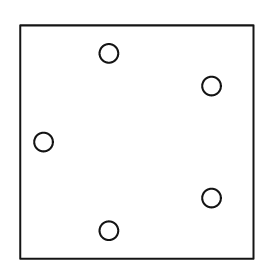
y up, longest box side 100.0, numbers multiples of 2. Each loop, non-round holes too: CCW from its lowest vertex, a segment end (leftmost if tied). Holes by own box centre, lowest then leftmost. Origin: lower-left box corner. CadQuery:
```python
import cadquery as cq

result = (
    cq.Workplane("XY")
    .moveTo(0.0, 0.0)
    .lineTo(100.0, 0.0)
    .lineTo(100.0, 100.0)
    .lineTo(0.0, 100.0)
    .close()
    .moveTo(38.0, 12.0)
    .circle(4.0)
    .moveTo(82.0, 26.0)
    .circle(4.0)
    .moveTo(10.0, 50.0)
    .circle(4.0)
    .moveTo(82.0, 74.0)
    .circle(4.0)
    .moveTo(38.0, 88.0)
    .circle(4.0)
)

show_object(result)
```